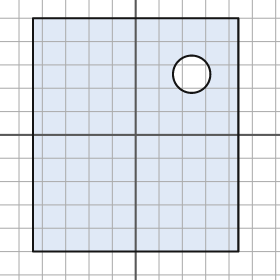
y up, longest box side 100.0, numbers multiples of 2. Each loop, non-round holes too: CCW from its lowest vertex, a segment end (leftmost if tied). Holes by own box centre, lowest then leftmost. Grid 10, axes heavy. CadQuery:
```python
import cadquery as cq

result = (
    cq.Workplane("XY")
    .moveTo(-44.0, -50.0)
    .lineTo(44.0, -50.0)
    .lineTo(44.0, 50.0)
    .lineTo(-44.0, 50.0)
    .close()
    .moveTo(24.0, 26.0)
    .circle(8.0)
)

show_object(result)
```